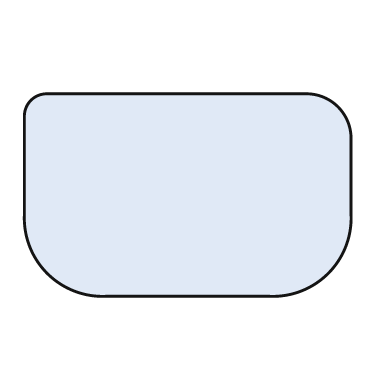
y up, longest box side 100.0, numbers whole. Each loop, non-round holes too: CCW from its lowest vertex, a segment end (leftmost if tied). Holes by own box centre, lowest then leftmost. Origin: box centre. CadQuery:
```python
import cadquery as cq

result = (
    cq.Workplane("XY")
    .moveTo(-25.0, -31.0)
    .lineTo(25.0, -31.0)
    .threePointArc((43.0, -24.0), (50.0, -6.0))
    .lineTo(50.0, 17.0)
    .threePointArc((46.0, 27.0), (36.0, 31.0))
    .lineTo(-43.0, 31.0)
    .threePointArc((-48.0, 29.0), (-50.0, 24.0))
    .lineTo(-50.0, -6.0)
    .threePointArc((-43.0, -24.0), (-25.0, -31.0))
    .close()
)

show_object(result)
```